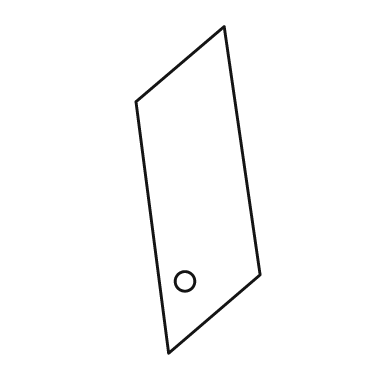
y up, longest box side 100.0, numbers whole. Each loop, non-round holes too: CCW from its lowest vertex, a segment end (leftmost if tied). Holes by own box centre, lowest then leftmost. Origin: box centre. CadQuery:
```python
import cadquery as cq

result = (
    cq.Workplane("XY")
    .moveTo(-9.0, -50.0)
    .lineTo(19.0, -26.0)
    .lineTo(8.0, 50.0)
    .lineTo(-19.0, 27.0)
    .close()
    .moveTo(-4.0, -28.0)
    .circle(3.0)
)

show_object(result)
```